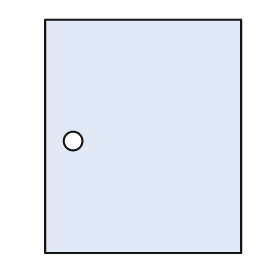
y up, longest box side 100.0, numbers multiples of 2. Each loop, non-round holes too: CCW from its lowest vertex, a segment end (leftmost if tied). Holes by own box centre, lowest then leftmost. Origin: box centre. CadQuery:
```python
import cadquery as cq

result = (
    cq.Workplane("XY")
    .moveTo(-42.0, -50.0)
    .lineTo(42.0, -50.0)
    .lineTo(42.0, 50.0)
    .lineTo(-42.0, 50.0)
    .close()
    .moveTo(-30.0, -2.0)
    .circle(4.0)
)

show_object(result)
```